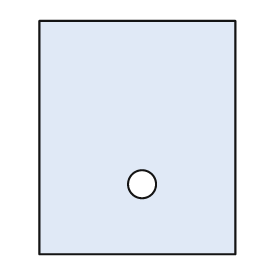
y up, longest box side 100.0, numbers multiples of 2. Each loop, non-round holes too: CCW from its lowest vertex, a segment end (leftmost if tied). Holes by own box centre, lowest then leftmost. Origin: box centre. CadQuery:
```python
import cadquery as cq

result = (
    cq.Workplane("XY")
    .moveTo(-42.0, -50.0)
    .lineTo(42.0, -50.0)
    .lineTo(42.0, 50.0)
    .lineTo(-42.0, 50.0)
    .close()
    .moveTo(2.0, -20.0)
    .circle(6.0)
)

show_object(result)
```